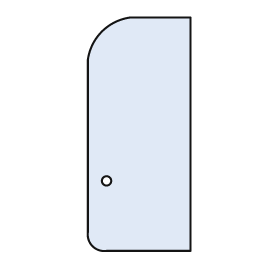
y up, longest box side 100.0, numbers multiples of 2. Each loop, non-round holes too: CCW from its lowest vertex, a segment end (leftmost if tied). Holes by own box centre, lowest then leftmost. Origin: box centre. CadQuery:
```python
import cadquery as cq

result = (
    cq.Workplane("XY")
    .moveTo(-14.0, -50.0)
    .lineTo(22.0, -50.0)
    .lineTo(22.0, 50.0)
    .lineTo(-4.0, 50.0)
    .threePointArc((-16.0, 44.0), (-22.0, 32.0))
    .lineTo(-22.0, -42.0)
    .threePointArc((-20.0, -48.0), (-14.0, -50.0))
    .close()
    .moveTo(-14.0, -20.0)
    .circle(2.0)
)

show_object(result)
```